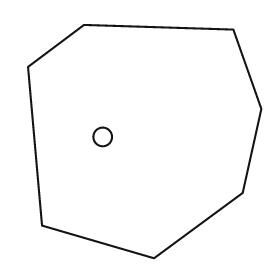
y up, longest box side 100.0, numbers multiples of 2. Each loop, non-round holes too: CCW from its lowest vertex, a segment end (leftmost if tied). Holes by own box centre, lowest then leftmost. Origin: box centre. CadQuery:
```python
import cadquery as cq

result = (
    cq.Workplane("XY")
    .moveTo(4.0, -50.0)
    .lineTo(42.0, -22.0)
    .lineTo(50.0, 14.0)
    .lineTo(38.0, 48.0)
    .lineTo(-26.0, 50.0)
    .lineTo(-50.0, 32.0)
    .lineTo(-44.0, -36.0)
    .close()
    .moveTo(-18.0, 2.0)
    .circle(4.0)
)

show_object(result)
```